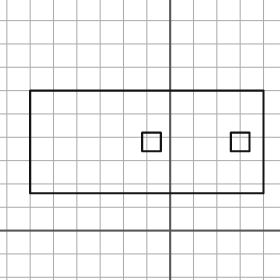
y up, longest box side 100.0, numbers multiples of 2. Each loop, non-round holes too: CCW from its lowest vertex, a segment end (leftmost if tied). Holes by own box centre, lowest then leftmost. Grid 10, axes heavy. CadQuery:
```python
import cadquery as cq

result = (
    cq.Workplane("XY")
    .moveTo(-60.0, 16.0)
    .lineTo(40.0, 16.0)
    .lineTo(40.0, 60.0)
    .lineTo(-60.0, 60.0)
    .close()
    .moveTo(-12.0, 34.0)
    .lineTo(-4.0, 34.0)
    .lineTo(-4.0, 42.0)
    .lineTo(-12.0, 42.0)
    .close()
    .moveTo(26.0, 34.0)
    .lineTo(34.0, 34.0)
    .lineTo(34.0, 42.0)
    .lineTo(26.0, 42.0)
    .close()
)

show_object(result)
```